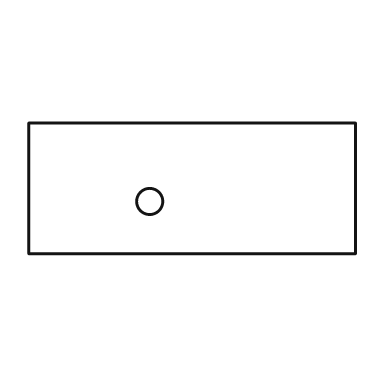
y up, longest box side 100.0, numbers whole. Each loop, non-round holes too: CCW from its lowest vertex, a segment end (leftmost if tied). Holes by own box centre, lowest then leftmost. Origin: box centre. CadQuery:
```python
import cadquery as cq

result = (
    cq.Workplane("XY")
    .moveTo(-50.0, -20.0)
    .lineTo(50.0, -20.0)
    .lineTo(50.0, 20.0)
    .lineTo(-50.0, 20.0)
    .close()
    .moveTo(-13.0, -4.0)
    .circle(4.0)
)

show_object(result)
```